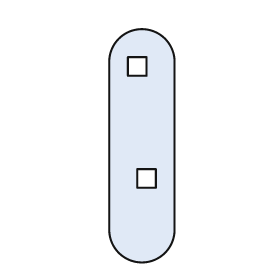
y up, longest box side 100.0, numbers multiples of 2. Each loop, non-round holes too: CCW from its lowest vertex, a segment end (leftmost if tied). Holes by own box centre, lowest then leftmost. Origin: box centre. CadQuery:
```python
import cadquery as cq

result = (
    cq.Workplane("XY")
    .moveTo(-14.0, -36.0)
    .threePointArc((0.0, -50.0), (14.0, -36.0))
    .lineTo(14.0, 36.0)
    .threePointArc((0.0, 50.0), (-14.0, 36.0))
    .close()
    .moveTo(-2.0, -18.0)
    .lineTo(6.0, -18.0)
    .lineTo(6.0, -10.0)
    .lineTo(-2.0, -10.0)
    .close()
    .moveTo(-6.0, 30.0)
    .lineTo(2.0, 30.0)
    .lineTo(2.0, 38.0)
    .lineTo(-6.0, 38.0)
    .close()
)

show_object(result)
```